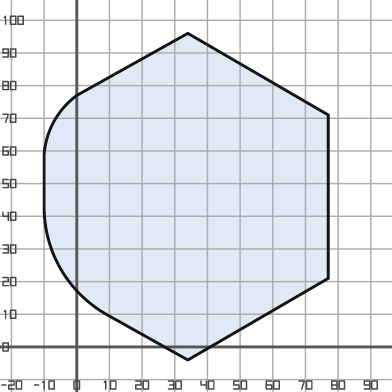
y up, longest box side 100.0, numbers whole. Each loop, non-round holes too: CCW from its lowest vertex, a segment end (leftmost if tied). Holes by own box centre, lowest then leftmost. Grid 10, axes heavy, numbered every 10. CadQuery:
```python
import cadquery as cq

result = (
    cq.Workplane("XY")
    .moveTo(34.0, -4.0)
    .lineTo(77.0, 21.0)
    .lineTo(77.0, 71.0)
    .lineTo(34.0, 96.0)
    .lineTo(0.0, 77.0)
    .threePointArc((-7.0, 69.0), (-10.0, 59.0))
    .lineTo(-10.0, 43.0)
    .threePointArc((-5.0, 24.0), (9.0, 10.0))
    .close()
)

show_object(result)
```